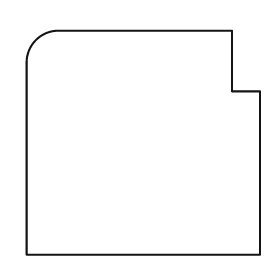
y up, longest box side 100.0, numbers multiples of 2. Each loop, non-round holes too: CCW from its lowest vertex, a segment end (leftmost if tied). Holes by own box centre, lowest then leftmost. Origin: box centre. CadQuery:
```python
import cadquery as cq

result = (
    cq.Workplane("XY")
    .moveTo(-50.0, -48.0)
    .lineTo(50.0, -48.0)
    .lineTo(50.0, 22.0)
    .lineTo(38.0, 22.0)
    .lineTo(38.0, 48.0)
    .lineTo(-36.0, 48.0)
    .threePointArc((-46.0, 44.0), (-50.0, 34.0))
    .close()
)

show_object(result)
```